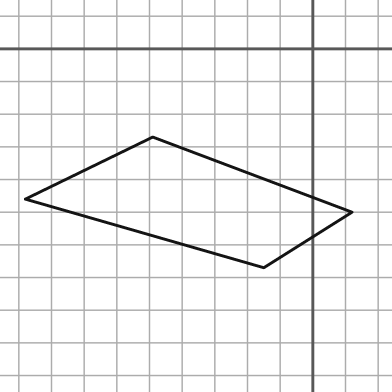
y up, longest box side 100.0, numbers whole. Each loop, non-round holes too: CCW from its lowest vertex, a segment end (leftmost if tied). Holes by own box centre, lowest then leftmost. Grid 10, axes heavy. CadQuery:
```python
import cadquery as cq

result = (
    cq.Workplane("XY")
    .moveTo(-15.0, -67.0)
    .lineTo(12.0, -50.0)
    .lineTo(-49.0, -27.0)
    .lineTo(-88.0, -46.0)
    .close()
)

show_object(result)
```